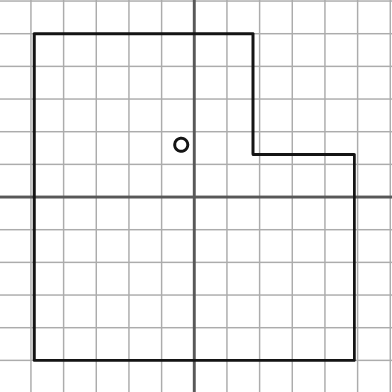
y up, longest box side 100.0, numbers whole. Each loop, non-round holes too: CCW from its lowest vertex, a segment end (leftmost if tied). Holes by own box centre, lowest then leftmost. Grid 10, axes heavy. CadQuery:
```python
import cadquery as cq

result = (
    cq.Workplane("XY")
    .moveTo(-49.0, -50.0)
    .lineTo(49.0, -50.0)
    .lineTo(49.0, 13.0)
    .lineTo(18.0, 13.0)
    .lineTo(18.0, 50.0)
    .lineTo(-49.0, 50.0)
    .close()
    .moveTo(-4.0, 16.0)
    .circle(2.0)
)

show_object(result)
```